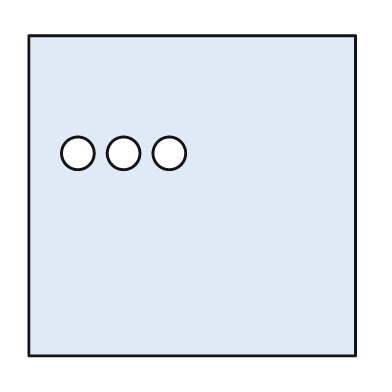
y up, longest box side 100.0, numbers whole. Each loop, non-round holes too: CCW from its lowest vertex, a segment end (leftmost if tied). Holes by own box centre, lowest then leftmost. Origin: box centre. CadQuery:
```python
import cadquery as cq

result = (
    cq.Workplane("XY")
    .moveTo(-50.0, -49.0)
    .lineTo(50.0, -49.0)
    .lineTo(50.0, 49.0)
    .lineTo(-50.0, 49.0)
    .close()
    .moveTo(-35.0, 13.0)
    .circle(5.0)
    .moveTo(-21.0, 13.0)
    .circle(5.0)
    .moveTo(-7.0, 13.0)
    .circle(5.0)
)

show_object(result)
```